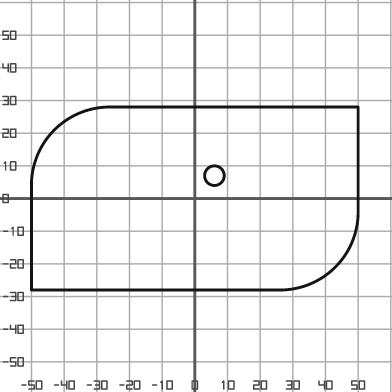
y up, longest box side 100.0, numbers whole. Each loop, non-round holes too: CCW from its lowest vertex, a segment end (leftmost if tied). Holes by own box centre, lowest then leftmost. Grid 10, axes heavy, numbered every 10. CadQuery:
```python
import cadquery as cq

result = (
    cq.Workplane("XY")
    .moveTo(-50.0, -28.0)
    .lineTo(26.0, -28.0)
    .threePointArc((43.0, -21.0), (50.0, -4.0))
    .lineTo(50.0, 28.0)
    .lineTo(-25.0, 28.0)
    .threePointArc((-43.0, 21.0), (-50.0, 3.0))
    .close()
    .moveTo(6.0, 7.0)
    .circle(3.0)
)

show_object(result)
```